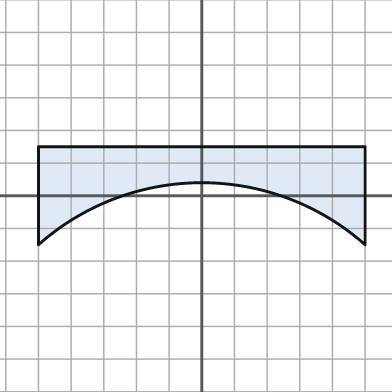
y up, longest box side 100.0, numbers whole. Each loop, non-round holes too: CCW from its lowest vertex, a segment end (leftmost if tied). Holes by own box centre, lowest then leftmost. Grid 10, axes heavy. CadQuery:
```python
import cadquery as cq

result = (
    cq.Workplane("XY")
    .moveTo(-50.0, -15.0)
    .threePointArc((0.0, 4.0), (50.0, -15.0))
    .lineTo(50.0, 15.0)
    .lineTo(-50.0, 15.0)
    .close()
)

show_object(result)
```